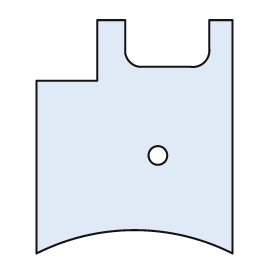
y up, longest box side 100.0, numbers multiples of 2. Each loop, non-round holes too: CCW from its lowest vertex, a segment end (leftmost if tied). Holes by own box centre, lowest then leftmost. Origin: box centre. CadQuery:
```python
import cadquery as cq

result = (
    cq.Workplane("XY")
    .moveTo(-42.0, -50.0)
    .threePointArc((0.0, -40.0), (42.0, -50.0))
    .lineTo(42.0, 50.0)
    .lineTo(32.0, 50.0)
    .lineTo(32.0, 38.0)
    .threePointArc((30.0, 32.0), (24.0, 30.0))
    .lineTo(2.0, 30.0)
    .threePointArc((-2.0, 32.0), (-4.0, 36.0))
    .lineTo(-4.0, 50.0)
    .lineTo(-16.0, 50.0)
    .lineTo(-16.0, 24.0)
    .lineTo(-42.0, 24.0)
    .close()
    .moveTo(10.0, -8.0)
    .circle(4.0)
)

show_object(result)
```